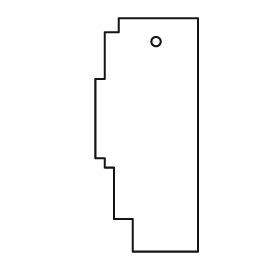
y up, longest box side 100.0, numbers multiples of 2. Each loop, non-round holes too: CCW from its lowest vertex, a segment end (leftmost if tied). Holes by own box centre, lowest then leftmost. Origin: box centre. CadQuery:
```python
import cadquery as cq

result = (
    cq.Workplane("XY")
    .moveTo(-6.0, -50.0)
    .lineTo(22.0, -50.0)
    .lineTo(22.0, 50.0)
    .lineTo(-12.0, 50.0)
    .lineTo(-12.0, 44.0)
    .lineTo(-18.0, 44.0)
    .lineTo(-18.0, 24.0)
    .lineTo(-22.0, 24.0)
    .lineTo(-22.0, -10.0)
    .lineTo(-18.0, -10.0)
    .lineTo(-18.0, -14.0)
    .lineTo(-14.0, -14.0)
    .lineTo(-14.0, -36.0)
    .lineTo(-6.0, -36.0)
    .close()
    .moveTo(4.0, 40.0)
    .circle(2.0)
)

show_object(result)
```